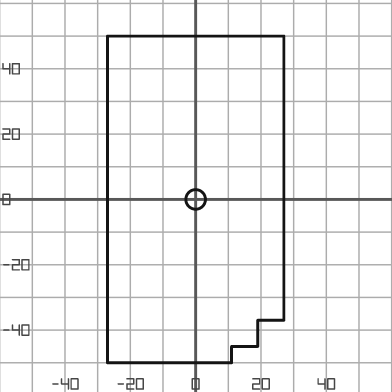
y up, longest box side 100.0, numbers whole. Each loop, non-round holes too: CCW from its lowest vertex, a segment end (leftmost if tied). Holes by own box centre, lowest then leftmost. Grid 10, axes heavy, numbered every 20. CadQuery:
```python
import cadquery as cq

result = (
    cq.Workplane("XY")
    .moveTo(-27.0, -50.0)
    .lineTo(11.0, -50.0)
    .lineTo(11.0, -45.0)
    .lineTo(19.0, -45.0)
    .lineTo(19.0, -37.0)
    .lineTo(27.0, -37.0)
    .lineTo(27.0, 50.0)
    .lineTo(-27.0, 50.0)
    .close()
    .moveTo(0.0, 0.0)
    .circle(3.0)
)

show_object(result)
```